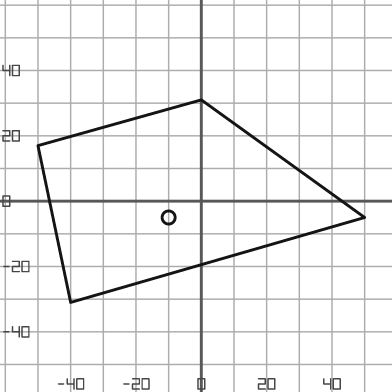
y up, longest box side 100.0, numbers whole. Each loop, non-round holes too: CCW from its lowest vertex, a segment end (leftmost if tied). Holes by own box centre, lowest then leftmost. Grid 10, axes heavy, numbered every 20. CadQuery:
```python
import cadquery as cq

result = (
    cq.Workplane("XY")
    .moveTo(-40.0, -31.0)
    .lineTo(50.0, -5.0)
    .lineTo(0.0, 31.0)
    .lineTo(-50.0, 17.0)
    .close()
    .moveTo(-10.0, -5.0)
    .circle(2.0)
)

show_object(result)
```